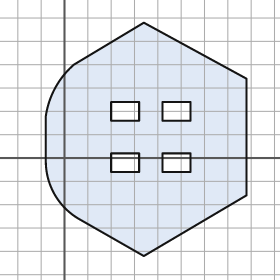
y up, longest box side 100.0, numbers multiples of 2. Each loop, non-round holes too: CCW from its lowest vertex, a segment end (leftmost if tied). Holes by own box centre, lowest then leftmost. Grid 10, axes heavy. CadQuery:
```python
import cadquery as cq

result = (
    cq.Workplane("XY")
    .moveTo(34.0, -42.0)
    .lineTo(78.0, -16.0)
    .lineTo(78.0, 34.0)
    .lineTo(34.0, 58.0)
    .lineTo(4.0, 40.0)
    .threePointArc((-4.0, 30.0), (-8.0, 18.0))
    .lineTo(-8.0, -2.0)
    .threePointArc((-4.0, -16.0), (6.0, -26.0))
    .close()
    .moveTo(20.0, -6.0)
    .lineTo(32.0, -6.0)
    .lineTo(32.0, 2.0)
    .lineTo(20.0, 2.0)
    .close()
    .moveTo(42.0, -6.0)
    .lineTo(54.0, -6.0)
    .lineTo(54.0, 2.0)
    .lineTo(42.0, 2.0)
    .close()
    .moveTo(20.0, 16.0)
    .lineTo(32.0, 16.0)
    .lineTo(32.0, 24.0)
    .lineTo(20.0, 24.0)
    .close()
    .moveTo(42.0, 16.0)
    .lineTo(54.0, 16.0)
    .lineTo(54.0, 24.0)
    .lineTo(42.0, 24.0)
    .close()
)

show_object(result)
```